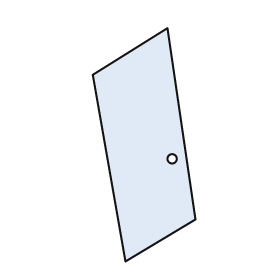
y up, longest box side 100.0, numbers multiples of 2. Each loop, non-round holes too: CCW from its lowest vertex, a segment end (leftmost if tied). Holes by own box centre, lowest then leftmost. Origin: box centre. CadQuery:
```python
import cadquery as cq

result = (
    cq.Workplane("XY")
    .moveTo(-8.0, -50.0)
    .lineTo(22.0, -32.0)
    .lineTo(10.0, 50.0)
    .lineTo(-22.0, 30.0)
    .close()
    .moveTo(12.0, -6.0)
    .circle(2.0)
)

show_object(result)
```